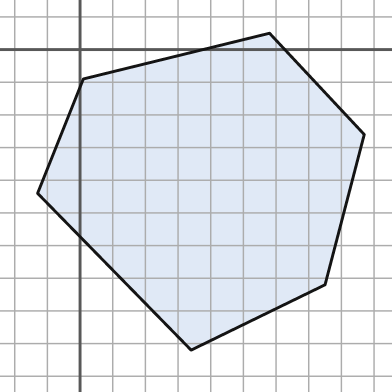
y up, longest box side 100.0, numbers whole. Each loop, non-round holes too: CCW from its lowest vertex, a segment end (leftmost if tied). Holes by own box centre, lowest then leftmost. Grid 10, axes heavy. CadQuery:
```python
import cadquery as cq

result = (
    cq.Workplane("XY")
    .moveTo(34.0, -92.0)
    .lineTo(75.0, -72.0)
    .lineTo(87.0, -26.0)
    .lineTo(58.0, 5.0)
    .lineTo(1.0, -9.0)
    .lineTo(-13.0, -44.0)
    .close()
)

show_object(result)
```